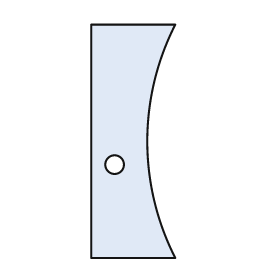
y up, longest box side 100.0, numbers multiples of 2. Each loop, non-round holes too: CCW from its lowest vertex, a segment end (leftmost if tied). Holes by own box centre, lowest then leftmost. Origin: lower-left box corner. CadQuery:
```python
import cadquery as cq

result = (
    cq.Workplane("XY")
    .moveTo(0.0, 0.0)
    .lineTo(36.0, 0.0)
    .threePointArc((24.0, 50.0), (36.0, 100.0))
    .lineTo(0.0, 100.0)
    .close()
    .moveTo(10.0, 40.0)
    .circle(4.0)
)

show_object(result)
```